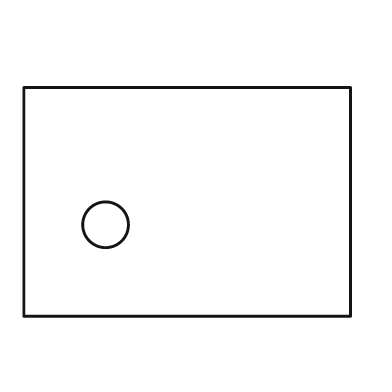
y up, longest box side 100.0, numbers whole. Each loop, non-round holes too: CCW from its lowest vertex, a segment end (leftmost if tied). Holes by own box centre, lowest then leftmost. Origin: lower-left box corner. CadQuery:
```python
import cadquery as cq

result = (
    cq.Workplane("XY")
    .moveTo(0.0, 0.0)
    .lineTo(100.0, 0.0)
    .lineTo(100.0, 70.0)
    .lineTo(0.0, 70.0)
    .close()
    .moveTo(25.0, 28.0)
    .circle(7.0)
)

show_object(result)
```